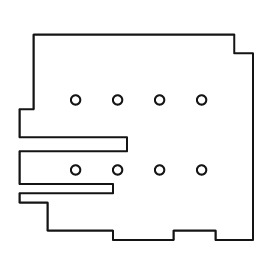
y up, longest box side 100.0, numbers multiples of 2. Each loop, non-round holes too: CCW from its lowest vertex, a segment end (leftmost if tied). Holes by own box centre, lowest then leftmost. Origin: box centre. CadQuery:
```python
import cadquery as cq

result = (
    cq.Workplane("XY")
    .moveTo(-10.0, -44.0)
    .lineTo(16.0, -44.0)
    .lineTo(16.0, -40.0)
    .lineTo(34.0, -40.0)
    .lineTo(34.0, -44.0)
    .lineTo(50.0, -44.0)
    .lineTo(50.0, 36.0)
    .lineTo(42.0, 36.0)
    .lineTo(42.0, 44.0)
    .lineTo(-44.0, 44.0)
    .lineTo(-44.0, 12.0)
    .lineTo(-50.0, 12.0)
    .lineTo(-50.0, 0.0)
    .lineTo(-4.0, 0.0)
    .lineTo(-4.0, -6.0)
    .lineTo(-50.0, -6.0)
    .lineTo(-50.0, -20.0)
    .lineTo(-10.0, -20.0)
    .lineTo(-10.0, -24.0)
    .lineTo(-50.0, -24.0)
    .lineTo(-50.0, -28.0)
    .lineTo(-38.0, -28.0)
    .lineTo(-38.0, -40.0)
    .lineTo(-10.0, -40.0)
    .close()
    .moveTo(-26.0, -14.0)
    .circle(2.0)
    .moveTo(-8.0, -14.0)
    .circle(2.0)
    .moveTo(10.0, -14.0)
    .circle(2.0)
    .moveTo(28.0, -14.0)
    .circle(2.0)
    .moveTo(-26.0, 16.0)
    .circle(2.0)
    .moveTo(-8.0, 16.0)
    .circle(2.0)
    .moveTo(10.0, 16.0)
    .circle(2.0)
    .moveTo(28.0, 16.0)
    .circle(2.0)
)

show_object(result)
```